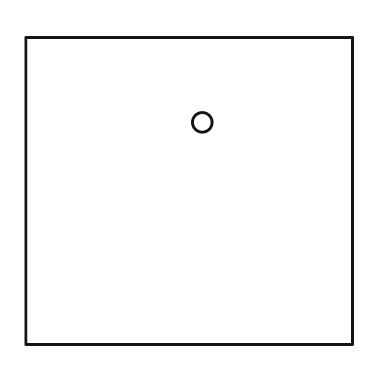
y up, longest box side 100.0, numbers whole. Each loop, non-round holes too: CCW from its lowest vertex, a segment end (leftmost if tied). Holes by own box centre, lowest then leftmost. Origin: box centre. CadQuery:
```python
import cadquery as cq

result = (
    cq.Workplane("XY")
    .moveTo(-50.0, -47.0)
    .lineTo(50.0, -47.0)
    .lineTo(50.0, 47.0)
    .lineTo(-50.0, 47.0)
    .close()
    .moveTo(4.0, 21.0)
    .circle(3.0)
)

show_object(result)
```